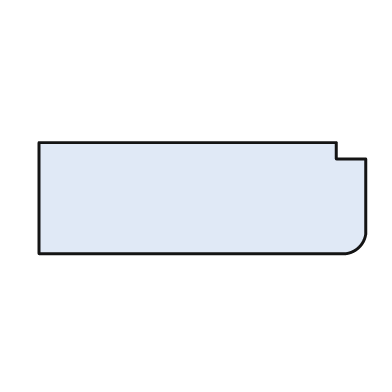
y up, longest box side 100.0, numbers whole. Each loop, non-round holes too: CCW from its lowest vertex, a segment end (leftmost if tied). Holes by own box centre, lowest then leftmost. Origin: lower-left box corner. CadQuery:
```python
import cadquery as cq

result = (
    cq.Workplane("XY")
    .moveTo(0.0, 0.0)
    .lineTo(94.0, 0.0)
    .threePointArc((98.0, 2.0), (100.0, 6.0))
    .lineTo(100.0, 29.0)
    .lineTo(91.0, 29.0)
    .lineTo(91.0, 34.0)
    .lineTo(0.0, 34.0)
    .close()
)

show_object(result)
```